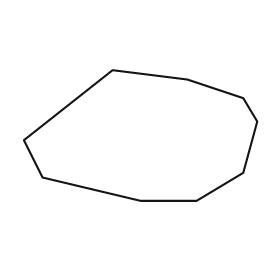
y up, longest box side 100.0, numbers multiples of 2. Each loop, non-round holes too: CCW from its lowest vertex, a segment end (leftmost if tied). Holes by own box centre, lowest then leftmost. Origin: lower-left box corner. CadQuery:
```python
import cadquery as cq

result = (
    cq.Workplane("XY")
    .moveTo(50.0, 0.0)
    .lineTo(74.0, 0.0)
    .lineTo(94.0, 12.0)
    .lineTo(100.0, 34.0)
    .lineTo(94.0, 44.0)
    .lineTo(70.0, 52.0)
    .lineTo(38.0, 56.0)
    .lineTo(0.0, 26.0)
    .lineTo(8.0, 10.0)
    .close()
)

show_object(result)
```